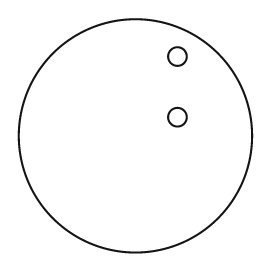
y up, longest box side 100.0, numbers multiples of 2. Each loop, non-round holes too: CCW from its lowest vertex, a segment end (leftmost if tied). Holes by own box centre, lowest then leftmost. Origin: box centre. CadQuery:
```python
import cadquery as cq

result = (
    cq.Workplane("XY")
    .moveTo(0.0, 0.0)
    .circle(50.0)
    .moveTo(18.0, 8.0)
    .circle(4.0)
    .moveTo(18.0, 34.0)
    .circle(4.0)
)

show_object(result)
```